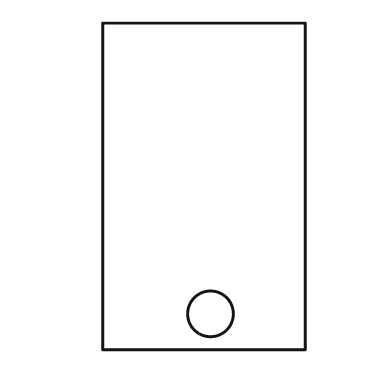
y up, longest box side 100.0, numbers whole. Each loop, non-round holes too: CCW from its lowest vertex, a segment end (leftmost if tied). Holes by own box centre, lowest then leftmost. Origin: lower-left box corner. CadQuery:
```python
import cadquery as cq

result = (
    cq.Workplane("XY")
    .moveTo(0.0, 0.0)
    .lineTo(62.0, 0.0)
    .lineTo(62.0, 100.0)
    .lineTo(0.0, 100.0)
    .close()
    .moveTo(33.0, 11.0)
    .circle(7.0)
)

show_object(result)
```